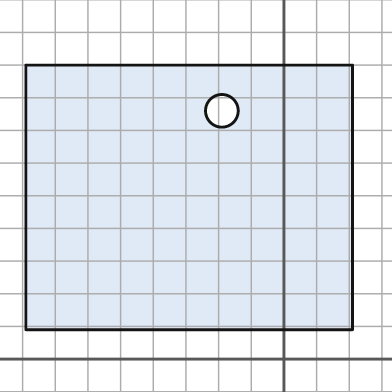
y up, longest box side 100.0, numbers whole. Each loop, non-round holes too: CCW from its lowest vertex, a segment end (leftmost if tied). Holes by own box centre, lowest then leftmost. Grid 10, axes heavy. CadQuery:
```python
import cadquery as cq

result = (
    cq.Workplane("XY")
    .moveTo(-79.0, 9.0)
    .lineTo(21.0, 9.0)
    .lineTo(21.0, 90.0)
    .lineTo(-79.0, 90.0)
    .close()
    .moveTo(-19.0, 76.0)
    .circle(5.0)
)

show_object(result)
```